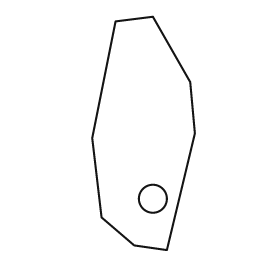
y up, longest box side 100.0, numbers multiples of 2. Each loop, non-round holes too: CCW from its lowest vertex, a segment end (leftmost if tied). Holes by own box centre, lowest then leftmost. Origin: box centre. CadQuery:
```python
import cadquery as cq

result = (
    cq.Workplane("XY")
    .moveTo(10.0, -50.0)
    .lineTo(22.0, 0.0)
    .lineTo(20.0, 22.0)
    .lineTo(4.0, 50.0)
    .lineTo(-12.0, 48.0)
    .lineTo(-22.0, -2.0)
    .lineTo(-18.0, -36.0)
    .lineTo(-4.0, -48.0)
    .close()
    .moveTo(4.0, -28.0)
    .circle(6.0)
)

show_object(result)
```